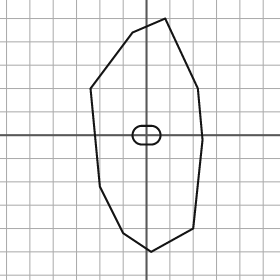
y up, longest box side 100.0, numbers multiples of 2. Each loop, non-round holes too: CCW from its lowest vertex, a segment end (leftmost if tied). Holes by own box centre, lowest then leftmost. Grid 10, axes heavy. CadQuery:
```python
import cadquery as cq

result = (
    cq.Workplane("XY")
    .moveTo(2.0, -50.0)
    .lineTo(20.0, -40.0)
    .lineTo(24.0, -2.0)
    .lineTo(22.0, 20.0)
    .lineTo(8.0, 50.0)
    .lineTo(-6.0, 44.0)
    .lineTo(-24.0, 20.0)
    .lineTo(-20.0, -22.0)
    .lineTo(-10.0, -42.0)
    .close()
    .moveTo(-2.0, -4.0)
    .lineTo(2.0, -4.0)
    .threePointArc((6.0, 0.0), (2.0, 4.0))
    .lineTo(-2.0, 4.0)
    .threePointArc((-6.0, 0.0), (-2.0, -4.0))
    .close()
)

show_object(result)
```